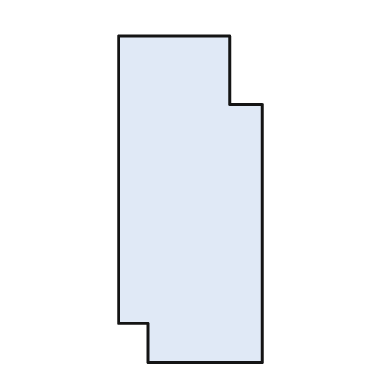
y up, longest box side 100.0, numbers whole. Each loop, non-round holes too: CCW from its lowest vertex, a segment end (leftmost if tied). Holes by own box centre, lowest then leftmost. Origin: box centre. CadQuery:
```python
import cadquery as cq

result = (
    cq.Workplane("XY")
    .moveTo(-13.0, -50.0)
    .lineTo(22.0, -50.0)
    .lineTo(22.0, 29.0)
    .lineTo(12.0, 29.0)
    .lineTo(12.0, 50.0)
    .lineTo(-22.0, 50.0)
    .lineTo(-22.0, -38.0)
    .lineTo(-13.0, -38.0)
    .close()
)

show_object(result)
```